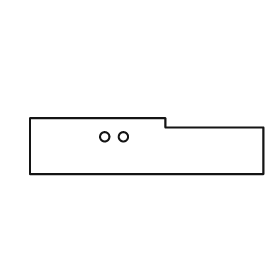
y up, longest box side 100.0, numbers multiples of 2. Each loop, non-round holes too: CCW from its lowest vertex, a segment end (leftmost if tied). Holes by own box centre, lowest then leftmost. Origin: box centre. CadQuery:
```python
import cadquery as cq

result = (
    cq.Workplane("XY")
    .moveTo(-50.0, -12.0)
    .lineTo(50.0, -12.0)
    .lineTo(50.0, 8.0)
    .lineTo(8.0, 8.0)
    .lineTo(8.0, 12.0)
    .lineTo(-50.0, 12.0)
    .close()
    .moveTo(-18.0, 4.0)
    .circle(2.0)
    .moveTo(-10.0, 4.0)
    .circle(2.0)
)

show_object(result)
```